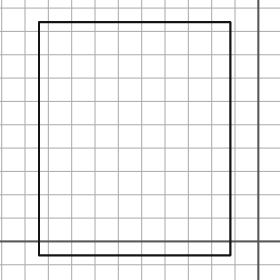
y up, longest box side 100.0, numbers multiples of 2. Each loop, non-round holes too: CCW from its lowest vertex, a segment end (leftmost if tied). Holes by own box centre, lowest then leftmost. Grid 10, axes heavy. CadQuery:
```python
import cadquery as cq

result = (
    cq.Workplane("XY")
    .moveTo(-94.0, -6.0)
    .lineTo(-12.0, -6.0)
    .lineTo(-12.0, 94.0)
    .lineTo(-94.0, 94.0)
    .close()
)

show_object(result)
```